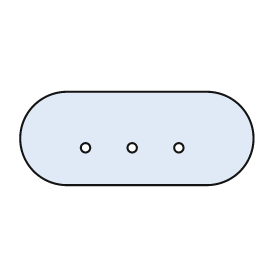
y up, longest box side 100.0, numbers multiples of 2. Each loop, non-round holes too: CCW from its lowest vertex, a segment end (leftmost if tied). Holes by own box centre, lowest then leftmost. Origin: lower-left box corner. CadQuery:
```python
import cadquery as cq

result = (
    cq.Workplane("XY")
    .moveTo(20.0, 0.0)
    .lineTo(80.0, 0.0)
    .threePointArc((100.0, 20.0), (80.0, 40.0))
    .lineTo(20.0, 40.0)
    .threePointArc((0.0, 20.0), (20.0, 0.0))
    .close()
    .moveTo(28.0, 16.0)
    .circle(2.0)
    .moveTo(48.0, 16.0)
    .circle(2.0)
    .moveTo(68.0, 16.0)
    .circle(2.0)
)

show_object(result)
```